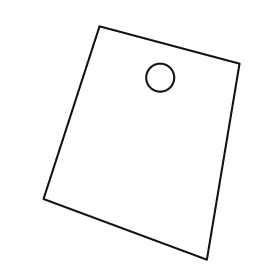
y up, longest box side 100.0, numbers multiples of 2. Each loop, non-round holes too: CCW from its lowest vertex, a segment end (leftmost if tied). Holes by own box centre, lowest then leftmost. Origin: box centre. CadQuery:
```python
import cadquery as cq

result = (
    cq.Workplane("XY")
    .moveTo(28.0, -50.0)
    .lineTo(42.0, 34.0)
    .lineTo(-18.0, 50.0)
    .lineTo(-42.0, -24.0)
    .close()
    .moveTo(8.0, 28.0)
    .circle(6.0)
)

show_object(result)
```